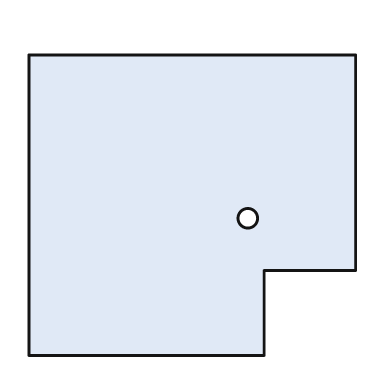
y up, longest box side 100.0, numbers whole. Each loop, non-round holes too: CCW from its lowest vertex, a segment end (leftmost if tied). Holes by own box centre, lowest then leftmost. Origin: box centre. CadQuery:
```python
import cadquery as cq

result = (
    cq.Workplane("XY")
    .moveTo(-50.0, -46.0)
    .lineTo(22.0, -46.0)
    .lineTo(22.0, -20.0)
    .lineTo(50.0, -20.0)
    .lineTo(50.0, 46.0)
    .lineTo(-50.0, 46.0)
    .close()
    .moveTo(17.0, -4.0)
    .circle(3.0)
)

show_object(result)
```